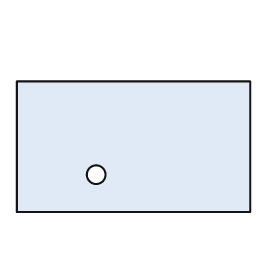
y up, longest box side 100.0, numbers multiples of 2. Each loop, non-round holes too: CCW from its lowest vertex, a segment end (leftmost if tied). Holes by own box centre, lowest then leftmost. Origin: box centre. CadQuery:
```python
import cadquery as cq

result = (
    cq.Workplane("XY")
    .moveTo(-50.0, -28.0)
    .lineTo(50.0, -28.0)
    .lineTo(50.0, 28.0)
    .lineTo(-50.0, 28.0)
    .close()
    .moveTo(-16.0, -12.0)
    .circle(4.0)
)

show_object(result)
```